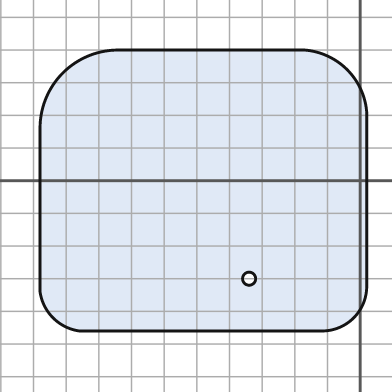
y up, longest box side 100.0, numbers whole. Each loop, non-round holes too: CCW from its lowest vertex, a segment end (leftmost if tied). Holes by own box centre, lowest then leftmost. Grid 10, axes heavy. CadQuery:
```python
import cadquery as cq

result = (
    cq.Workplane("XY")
    .moveTo(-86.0, -46.0)
    .lineTo(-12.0, -46.0)
    .threePointArc((-2.0, -42.0), (2.0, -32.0))
    .lineTo(2.0, 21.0)
    .threePointArc((-4.0, 34.0), (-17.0, 40.0))
    .lineTo(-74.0, 40.0)
    .threePointArc((-91.0, 33.0), (-98.0, 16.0))
    .lineTo(-98.0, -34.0)
    .threePointArc((-94.0, -42.0), (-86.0, -46.0))
    .close()
    .moveTo(-34.0, -30.0)
    .circle(2.0)
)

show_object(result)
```